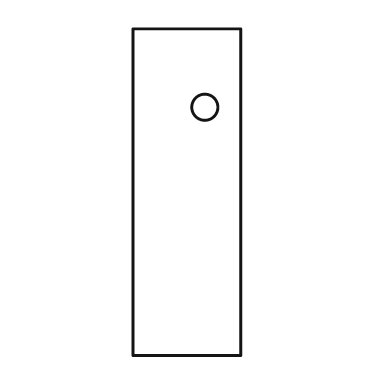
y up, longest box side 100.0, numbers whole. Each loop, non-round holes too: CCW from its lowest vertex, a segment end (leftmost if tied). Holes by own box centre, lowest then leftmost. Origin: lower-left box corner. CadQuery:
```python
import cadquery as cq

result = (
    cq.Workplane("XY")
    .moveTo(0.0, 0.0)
    .lineTo(33.0, 0.0)
    .lineTo(33.0, 100.0)
    .lineTo(0.0, 100.0)
    .close()
    .moveTo(22.0, 76.0)
    .circle(4.0)
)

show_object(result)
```